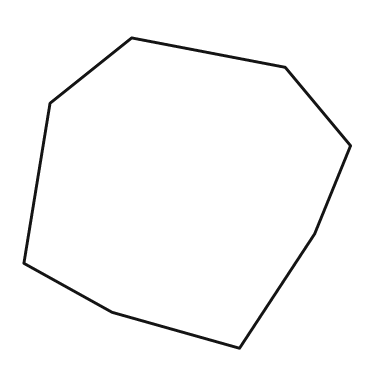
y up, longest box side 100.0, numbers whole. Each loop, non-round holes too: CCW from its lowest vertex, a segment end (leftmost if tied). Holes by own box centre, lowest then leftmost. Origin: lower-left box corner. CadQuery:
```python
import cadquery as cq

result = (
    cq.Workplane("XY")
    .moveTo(66.0, 0.0)
    .lineTo(89.0, 35.0)
    .lineTo(100.0, 62.0)
    .lineTo(80.0, 86.0)
    .lineTo(33.0, 95.0)
    .lineTo(8.0, 75.0)
    .lineTo(0.0, 26.0)
    .lineTo(27.0, 11.0)
    .close()
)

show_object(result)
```